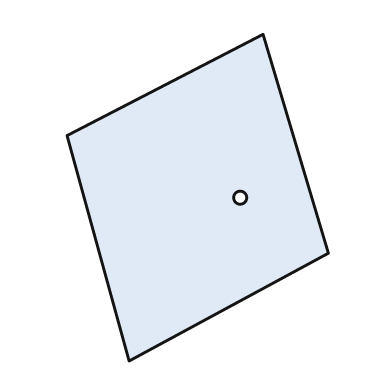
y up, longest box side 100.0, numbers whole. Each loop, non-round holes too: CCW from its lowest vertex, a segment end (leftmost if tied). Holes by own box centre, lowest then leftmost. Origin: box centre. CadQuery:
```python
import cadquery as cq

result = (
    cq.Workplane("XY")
    .moveTo(-21.0, -50.0)
    .lineTo(40.0, -17.0)
    .lineTo(20.0, 50.0)
    .lineTo(-40.0, 19.0)
    .close()
    .moveTo(13.0, 0.0)
    .circle(2.0)
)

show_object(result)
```